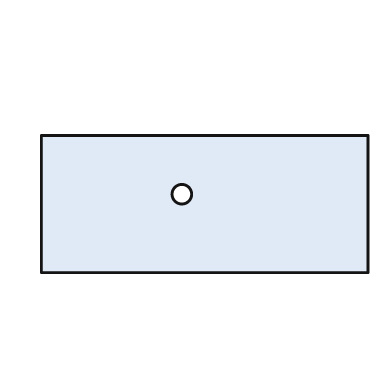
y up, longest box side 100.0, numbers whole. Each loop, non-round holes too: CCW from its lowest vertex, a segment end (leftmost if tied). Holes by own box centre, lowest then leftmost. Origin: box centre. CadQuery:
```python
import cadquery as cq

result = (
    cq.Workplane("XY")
    .moveTo(-50.0, -21.0)
    .lineTo(50.0, -21.0)
    .lineTo(50.0, 21.0)
    .lineTo(-50.0, 21.0)
    .close()
    .moveTo(-7.0, 3.0)
    .circle(3.0)
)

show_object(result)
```